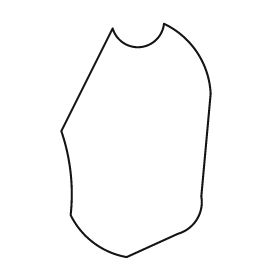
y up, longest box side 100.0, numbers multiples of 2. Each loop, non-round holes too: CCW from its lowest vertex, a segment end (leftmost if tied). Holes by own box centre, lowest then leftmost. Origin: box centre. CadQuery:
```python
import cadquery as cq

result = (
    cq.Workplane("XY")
    .moveTo(-4.0, -50.0)
    .lineTo(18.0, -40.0)
    .threePointArc((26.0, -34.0), (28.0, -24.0))
    .lineTo(32.0, 20.0)
    .threePointArc((26.0, 38.0), (12.0, 50.0))
    .threePointArc((2.0, 40.0), (-10.0, 48.0))
    .lineTo(-32.0, 4.0)
    .threePointArc((-28.0, -14.0), (-28.0, -32.0))
    .threePointArc((-18.0, -44.0), (-4.0, -50.0))
    .close()
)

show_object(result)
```